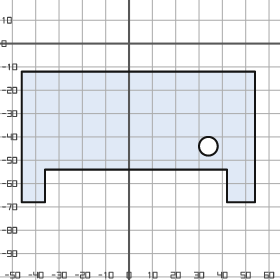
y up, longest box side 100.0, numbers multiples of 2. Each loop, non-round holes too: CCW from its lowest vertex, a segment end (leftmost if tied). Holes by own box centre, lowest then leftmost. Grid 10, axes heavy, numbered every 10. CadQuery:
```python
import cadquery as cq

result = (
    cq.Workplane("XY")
    .moveTo(-46.0, -68.0)
    .lineTo(-36.0, -68.0)
    .lineTo(-36.0, -54.0)
    .lineTo(42.0, -54.0)
    .lineTo(42.0, -68.0)
    .lineTo(54.0, -68.0)
    .lineTo(54.0, -12.0)
    .lineTo(-46.0, -12.0)
    .close()
    .moveTo(34.0, -44.0)
    .circle(4.0)
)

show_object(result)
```